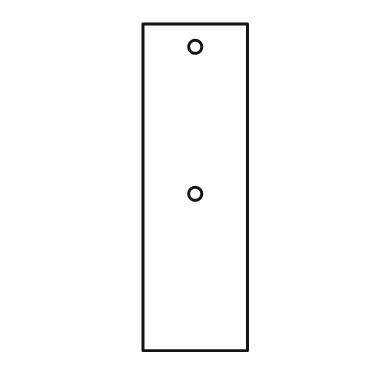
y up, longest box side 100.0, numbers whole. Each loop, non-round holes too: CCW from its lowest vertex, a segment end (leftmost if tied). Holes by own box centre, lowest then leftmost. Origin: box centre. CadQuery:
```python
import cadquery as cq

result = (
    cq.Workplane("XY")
    .moveTo(-16.0, -50.0)
    .lineTo(16.0, -50.0)
    .lineTo(16.0, 50.0)
    .lineTo(-16.0, 50.0)
    .close()
    .moveTo(0.0, -2.0)
    .circle(2.0)
    .moveTo(0.0, 43.0)
    .circle(2.0)
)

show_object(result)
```